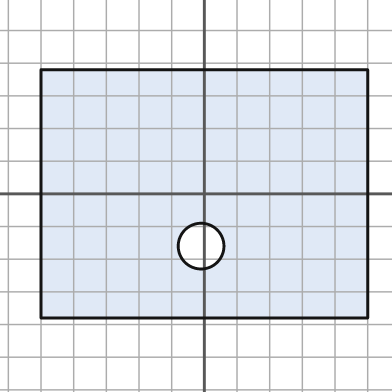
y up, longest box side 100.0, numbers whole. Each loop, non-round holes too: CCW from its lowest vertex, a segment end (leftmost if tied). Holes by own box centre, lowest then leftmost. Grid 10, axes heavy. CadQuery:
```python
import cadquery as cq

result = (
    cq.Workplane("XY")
    .moveTo(-50.0, -38.0)
    .lineTo(50.0, -38.0)
    .lineTo(50.0, 38.0)
    .lineTo(-50.0, 38.0)
    .close()
    .moveTo(-1.0, -16.0)
    .circle(7.0)
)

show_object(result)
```